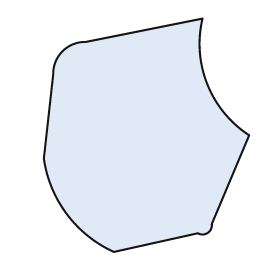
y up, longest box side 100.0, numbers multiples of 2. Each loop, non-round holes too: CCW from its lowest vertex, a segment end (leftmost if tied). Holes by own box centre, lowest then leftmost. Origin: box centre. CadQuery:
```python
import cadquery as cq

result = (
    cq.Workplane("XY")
    .moveTo(-14.0, -50.0)
    .lineTo(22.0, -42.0)
    .threePointArc((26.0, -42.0), (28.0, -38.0))
    .lineTo(44.0, 0.0)
    .threePointArc((26.0, 22.0), (24.0, 50.0))
    .lineTo(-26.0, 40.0)
    .threePointArc((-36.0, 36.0), (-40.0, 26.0))
    .lineTo(-44.0, -10.0)
    .threePointArc((-34.0, -34.0), (-14.0, -50.0))
    .close()
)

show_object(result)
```